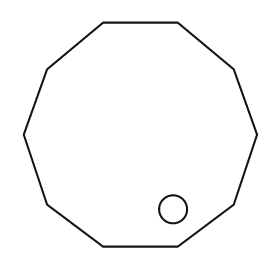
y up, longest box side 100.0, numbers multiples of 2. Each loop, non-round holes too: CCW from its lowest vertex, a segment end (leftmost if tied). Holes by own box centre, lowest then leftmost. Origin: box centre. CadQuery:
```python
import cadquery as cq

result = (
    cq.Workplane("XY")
    .moveTo(-16.0, -48.0)
    .lineTo(16.0, -48.0)
    .lineTo(40.0, -30.0)
    .lineTo(50.0, 0.0)
    .lineTo(40.0, 28.0)
    .lineTo(16.0, 48.0)
    .lineTo(-16.0, 48.0)
    .lineTo(-40.0, 28.0)
    .lineTo(-50.0, 0.0)
    .lineTo(-40.0, -30.0)
    .close()
    .moveTo(14.0, -32.0)
    .circle(6.0)
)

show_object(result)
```